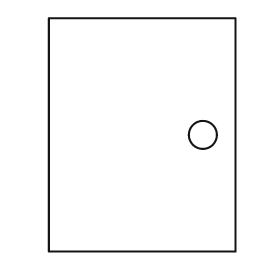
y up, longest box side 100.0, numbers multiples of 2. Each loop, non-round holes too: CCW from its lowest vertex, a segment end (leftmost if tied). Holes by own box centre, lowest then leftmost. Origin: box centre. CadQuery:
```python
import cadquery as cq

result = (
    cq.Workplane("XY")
    .moveTo(-40.0, -50.0)
    .lineTo(40.0, -50.0)
    .lineTo(40.0, 50.0)
    .lineTo(-40.0, 50.0)
    .close()
    .moveTo(26.0, 0.0)
    .circle(6.0)
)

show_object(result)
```